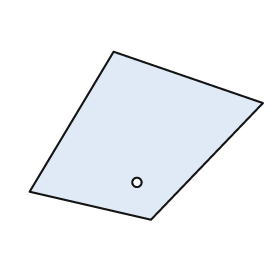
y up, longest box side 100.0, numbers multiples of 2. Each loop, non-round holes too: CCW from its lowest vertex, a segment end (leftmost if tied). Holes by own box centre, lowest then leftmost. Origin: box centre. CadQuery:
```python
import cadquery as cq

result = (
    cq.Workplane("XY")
    .moveTo(2.0, -36.0)
    .lineTo(50.0, 14.0)
    .lineTo(-14.0, 36.0)
    .lineTo(-50.0, -24.0)
    .close()
    .moveTo(-4.0, -20.0)
    .circle(2.0)
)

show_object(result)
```